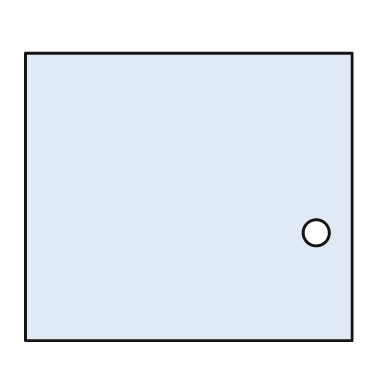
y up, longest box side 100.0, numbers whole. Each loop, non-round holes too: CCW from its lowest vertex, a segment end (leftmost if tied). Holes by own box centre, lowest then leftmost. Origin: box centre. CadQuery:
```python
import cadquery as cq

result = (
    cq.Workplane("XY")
    .moveTo(-50.0, -44.0)
    .lineTo(50.0, -44.0)
    .lineTo(50.0, 44.0)
    .lineTo(-50.0, 44.0)
    .close()
    .moveTo(39.0, -11.0)
    .circle(4.0)
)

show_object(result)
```